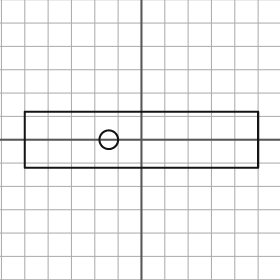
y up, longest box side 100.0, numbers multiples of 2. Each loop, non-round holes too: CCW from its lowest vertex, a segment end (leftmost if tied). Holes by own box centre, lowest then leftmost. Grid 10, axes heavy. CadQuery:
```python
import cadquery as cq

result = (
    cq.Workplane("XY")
    .moveTo(-50.0, -12.0)
    .lineTo(50.0, -12.0)
    .lineTo(50.0, 12.0)
    .lineTo(-50.0, 12.0)
    .close()
    .moveTo(-14.0, 0.0)
    .circle(4.0)
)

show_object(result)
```